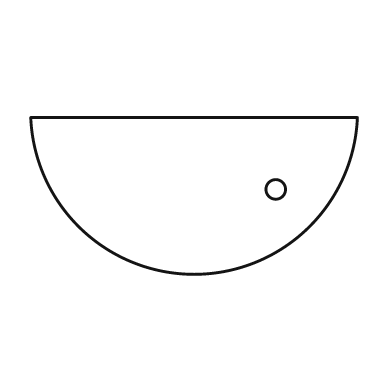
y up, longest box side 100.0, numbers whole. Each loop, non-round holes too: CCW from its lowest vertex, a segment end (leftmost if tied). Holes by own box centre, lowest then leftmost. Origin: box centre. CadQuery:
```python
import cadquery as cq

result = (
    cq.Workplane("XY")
    .moveTo(-50.0, 24.0)
    .threePointArc((0.0, -24.0), (50.0, 24.0))
    .close()
    .moveTo(25.0, 2.0)
    .circle(3.0)
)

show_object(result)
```